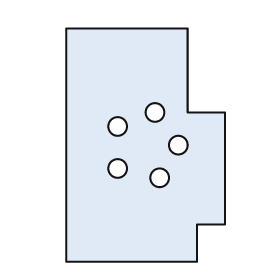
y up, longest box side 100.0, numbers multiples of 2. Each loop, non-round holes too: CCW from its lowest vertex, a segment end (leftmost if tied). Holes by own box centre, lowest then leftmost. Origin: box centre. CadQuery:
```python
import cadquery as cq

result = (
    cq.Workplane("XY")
    .moveTo(-34.0, -50.0)
    .lineTo(22.0, -50.0)
    .lineTo(22.0, -34.0)
    .lineTo(34.0, -34.0)
    .lineTo(34.0, 14.0)
    .lineTo(18.0, 14.0)
    .lineTo(18.0, 50.0)
    .lineTo(-34.0, 50.0)
    .close()
    .moveTo(6.0, -14.0)
    .circle(4.0)
    .moveTo(-12.0, -10.0)
    .circle(4.0)
    .moveTo(14.0, 0.0)
    .circle(4.0)
    .moveTo(-12.0, 8.0)
    .circle(4.0)
    .moveTo(4.0, 14.0)
    .circle(4.0)
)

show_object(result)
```